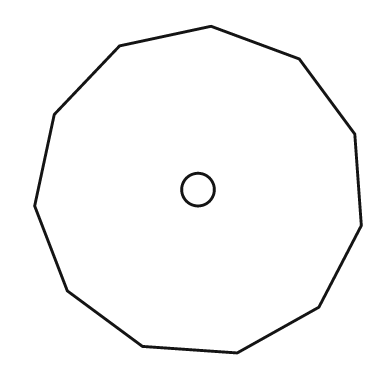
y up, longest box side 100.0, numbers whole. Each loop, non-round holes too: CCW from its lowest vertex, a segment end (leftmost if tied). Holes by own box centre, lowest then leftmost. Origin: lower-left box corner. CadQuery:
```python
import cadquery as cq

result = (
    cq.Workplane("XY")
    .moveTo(62.0, 0.0)
    .lineTo(87.0, 14.0)
    .lineTo(100.0, 39.0)
    .lineTo(98.0, 67.0)
    .lineTo(81.0, 90.0)
    .lineTo(54.0, 100.0)
    .lineTo(26.0, 94.0)
    .lineTo(6.0, 73.0)
    .lineTo(0.0, 45.0)
    .lineTo(10.0, 19.0)
    .lineTo(33.0, 2.0)
    .close()
    .moveTo(50.0, 50.0)
    .circle(5.0)
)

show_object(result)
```